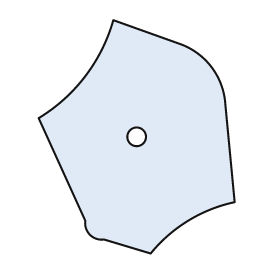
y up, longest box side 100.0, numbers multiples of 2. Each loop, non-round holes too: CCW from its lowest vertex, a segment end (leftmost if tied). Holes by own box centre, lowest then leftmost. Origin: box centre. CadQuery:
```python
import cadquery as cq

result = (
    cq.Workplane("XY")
    .moveTo(6.0, -50.0)
    .threePointArc((22.0, -36.0), (42.0, -28.0))
    .lineTo(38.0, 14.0)
    .threePointArc((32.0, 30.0), (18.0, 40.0))
    .lineTo(-10.0, 50.0)
    .threePointArc((-22.0, 26.0), (-42.0, 8.0))
    .lineTo(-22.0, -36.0)
    .threePointArc((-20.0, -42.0), (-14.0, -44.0))
    .close()
    .moveTo(0.0, 0.0)
    .circle(4.0)
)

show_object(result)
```